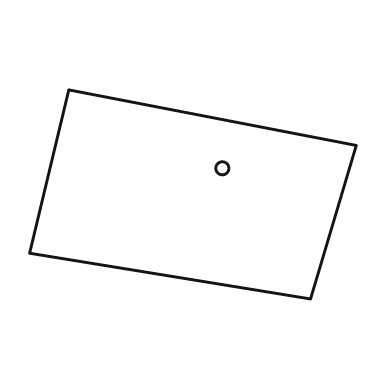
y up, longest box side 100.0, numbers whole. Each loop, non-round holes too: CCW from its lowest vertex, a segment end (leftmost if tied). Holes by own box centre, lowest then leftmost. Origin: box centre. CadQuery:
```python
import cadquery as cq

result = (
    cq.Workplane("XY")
    .moveTo(36.0, -32.0)
    .lineTo(50.0, 15.0)
    .lineTo(-38.0, 32.0)
    .lineTo(-50.0, -18.0)
    .close()
    .moveTo(9.0, 8.0)
    .circle(2.0)
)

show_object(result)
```